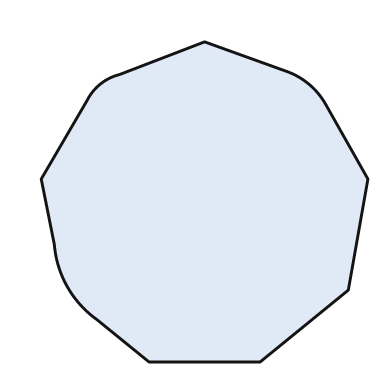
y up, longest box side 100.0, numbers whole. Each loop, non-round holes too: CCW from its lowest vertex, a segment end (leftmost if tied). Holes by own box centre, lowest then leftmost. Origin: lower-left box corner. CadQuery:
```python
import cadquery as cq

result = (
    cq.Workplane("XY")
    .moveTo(33.0, 0.0)
    .lineTo(67.0, 0.0)
    .lineTo(94.0, 22.0)
    .lineTo(100.0, 56.0)
    .lineTo(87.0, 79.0)
    .threePointArc((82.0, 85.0), (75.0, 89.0))
    .lineTo(50.0, 98.0)
    .lineTo(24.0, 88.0)
    .threePointArc((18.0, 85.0), (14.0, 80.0))
    .lineTo(0.0, 56.0)
    .lineTo(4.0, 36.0)
    .threePointArc((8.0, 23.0), (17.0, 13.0))
    .close()
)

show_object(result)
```